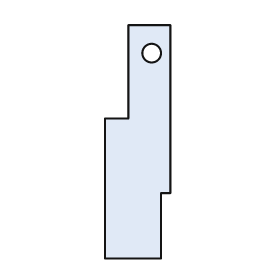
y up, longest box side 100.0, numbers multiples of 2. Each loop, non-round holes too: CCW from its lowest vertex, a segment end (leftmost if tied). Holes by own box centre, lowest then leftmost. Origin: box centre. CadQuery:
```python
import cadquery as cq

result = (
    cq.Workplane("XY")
    .moveTo(-14.0, -50.0)
    .lineTo(10.0, -50.0)
    .lineTo(10.0, -22.0)
    .lineTo(14.0, -22.0)
    .lineTo(14.0, 50.0)
    .lineTo(-4.0, 50.0)
    .lineTo(-4.0, 10.0)
    .lineTo(-14.0, 10.0)
    .close()
    .moveTo(6.0, 38.0)
    .circle(4.0)
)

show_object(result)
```